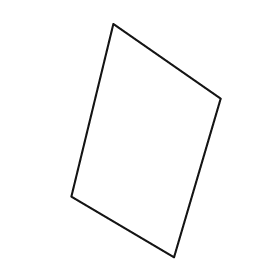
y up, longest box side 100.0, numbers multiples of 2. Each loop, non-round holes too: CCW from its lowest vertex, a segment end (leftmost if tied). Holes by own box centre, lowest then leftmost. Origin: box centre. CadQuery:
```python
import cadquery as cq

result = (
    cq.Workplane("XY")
    .moveTo(12.0, -50.0)
    .lineTo(32.0, 18.0)
    .lineTo(-14.0, 50.0)
    .lineTo(-32.0, -24.0)
    .close()
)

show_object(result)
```